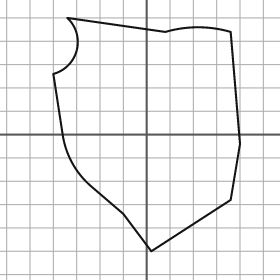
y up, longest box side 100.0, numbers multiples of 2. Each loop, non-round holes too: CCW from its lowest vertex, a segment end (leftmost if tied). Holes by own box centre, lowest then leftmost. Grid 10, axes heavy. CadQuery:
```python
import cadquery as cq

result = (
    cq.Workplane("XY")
    .moveTo(2.0, -50.0)
    .lineTo(36.0, -28.0)
    .lineTo(40.0, -4.0)
    .lineTo(36.0, 44.0)
    .threePointArc((22.0, 46.0), (8.0, 44.0))
    .lineTo(-34.0, 50.0)
    .threePointArc((-30.0, 36.0), (-40.0, 26.0))
    .lineTo(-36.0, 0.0)
    .threePointArc((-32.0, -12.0), (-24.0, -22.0))
    .lineTo(-10.0, -34.0)
    .close()
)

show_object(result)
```